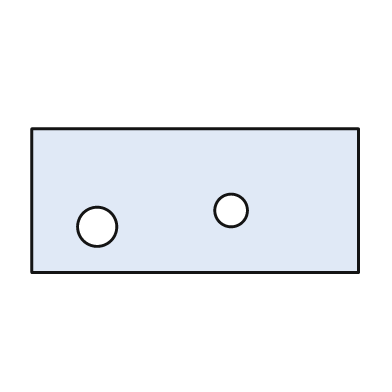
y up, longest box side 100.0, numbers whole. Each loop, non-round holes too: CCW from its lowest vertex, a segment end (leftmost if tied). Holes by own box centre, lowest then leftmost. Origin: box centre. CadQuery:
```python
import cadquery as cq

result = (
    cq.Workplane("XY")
    .moveTo(-50.0, -22.0)
    .lineTo(50.0, -22.0)
    .lineTo(50.0, 22.0)
    .lineTo(-50.0, 22.0)
    .close()
    .moveTo(-30.0, -8.0)
    .circle(6.0)
    .moveTo(11.0, -3.0)
    .circle(5.0)
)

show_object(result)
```